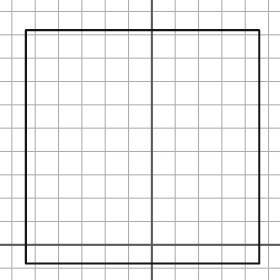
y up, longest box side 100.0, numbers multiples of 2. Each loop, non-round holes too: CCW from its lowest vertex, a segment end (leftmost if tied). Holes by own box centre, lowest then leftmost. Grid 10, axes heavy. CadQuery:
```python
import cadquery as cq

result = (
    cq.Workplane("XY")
    .moveTo(-54.0, -8.0)
    .lineTo(46.0, -8.0)
    .lineTo(46.0, 92.0)
    .lineTo(-54.0, 92.0)
    .close()
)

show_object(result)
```